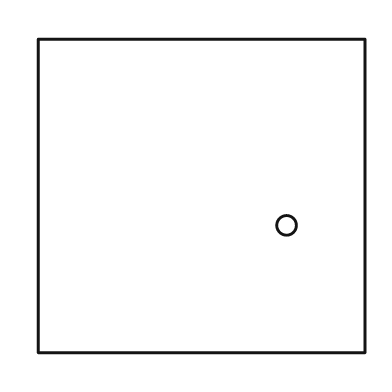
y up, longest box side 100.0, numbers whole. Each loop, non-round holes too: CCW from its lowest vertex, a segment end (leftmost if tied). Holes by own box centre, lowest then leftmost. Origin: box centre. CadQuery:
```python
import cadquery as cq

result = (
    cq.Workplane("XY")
    .moveTo(-50.0, -48.0)
    .lineTo(50.0, -48.0)
    .lineTo(50.0, 48.0)
    .lineTo(-50.0, 48.0)
    .close()
    .moveTo(26.0, -9.0)
    .circle(3.0)
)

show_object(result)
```